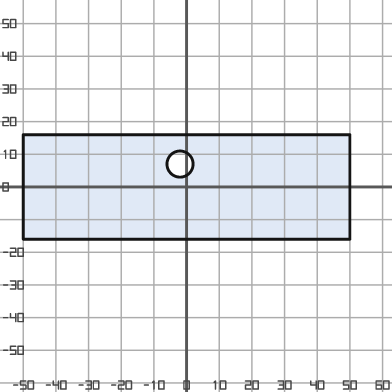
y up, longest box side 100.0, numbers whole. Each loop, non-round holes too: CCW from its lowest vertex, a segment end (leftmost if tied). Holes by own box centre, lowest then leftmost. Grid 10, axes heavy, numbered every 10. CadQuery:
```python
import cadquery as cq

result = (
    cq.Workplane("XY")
    .moveTo(-50.0, -16.0)
    .lineTo(50.0, -16.0)
    .lineTo(50.0, 16.0)
    .lineTo(-50.0, 16.0)
    .close()
    .moveTo(-2.0, 7.0)
    .circle(4.0)
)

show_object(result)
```